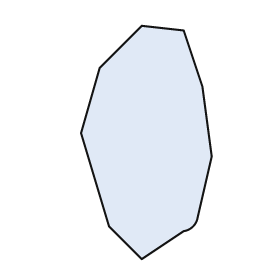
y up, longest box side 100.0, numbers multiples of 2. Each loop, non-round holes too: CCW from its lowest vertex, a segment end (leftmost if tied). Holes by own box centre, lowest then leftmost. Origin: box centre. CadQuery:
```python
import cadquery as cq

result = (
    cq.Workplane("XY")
    .moveTo(-2.0, -50.0)
    .lineTo(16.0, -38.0)
    .threePointArc((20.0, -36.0), (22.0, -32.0))
    .lineTo(28.0, -6.0)
    .lineTo(24.0, 24.0)
    .lineTo(16.0, 48.0)
    .lineTo(-2.0, 50.0)
    .lineTo(-20.0, 32.0)
    .lineTo(-28.0, 4.0)
    .lineTo(-16.0, -36.0)
    .close()
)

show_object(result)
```